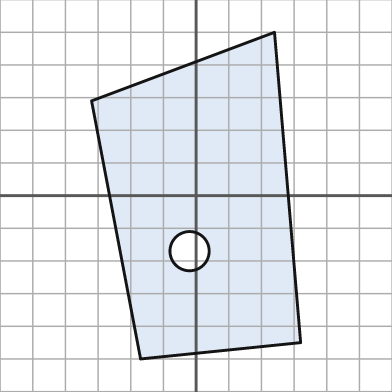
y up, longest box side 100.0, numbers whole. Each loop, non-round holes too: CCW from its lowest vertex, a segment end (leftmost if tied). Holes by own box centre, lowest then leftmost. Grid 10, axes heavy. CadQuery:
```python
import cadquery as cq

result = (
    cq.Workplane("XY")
    .moveTo(-17.0, -50.0)
    .lineTo(32.0, -45.0)
    .lineTo(24.0, 50.0)
    .lineTo(-32.0, 29.0)
    .close()
    .moveTo(-2.0, -17.0)
    .circle(6.0)
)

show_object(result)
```